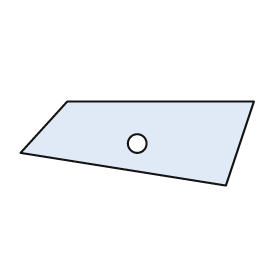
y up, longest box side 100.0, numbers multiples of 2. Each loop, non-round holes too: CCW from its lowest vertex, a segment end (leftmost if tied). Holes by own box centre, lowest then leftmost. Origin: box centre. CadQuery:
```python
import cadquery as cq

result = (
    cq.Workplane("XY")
    .moveTo(38.0, -18.0)
    .lineTo(50.0, 18.0)
    .lineTo(-30.0, 18.0)
    .lineTo(-50.0, -4.0)
    .close()
    .moveTo(0.0, 0.0)
    .circle(4.0)
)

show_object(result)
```